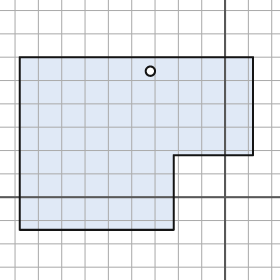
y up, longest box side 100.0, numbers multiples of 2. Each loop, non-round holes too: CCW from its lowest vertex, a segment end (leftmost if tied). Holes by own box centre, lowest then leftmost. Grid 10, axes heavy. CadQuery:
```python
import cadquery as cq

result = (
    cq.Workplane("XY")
    .moveTo(-88.0, -14.0)
    .lineTo(-22.0, -14.0)
    .lineTo(-22.0, 18.0)
    .lineTo(12.0, 18.0)
    .lineTo(12.0, 60.0)
    .lineTo(-88.0, 60.0)
    .close()
    .moveTo(-32.0, 54.0)
    .circle(2.0)
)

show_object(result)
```